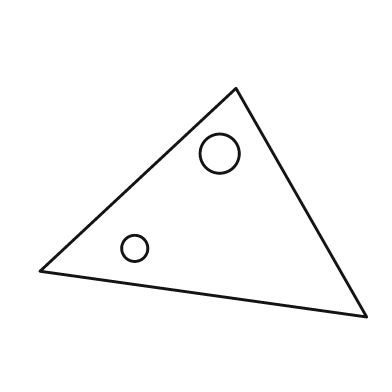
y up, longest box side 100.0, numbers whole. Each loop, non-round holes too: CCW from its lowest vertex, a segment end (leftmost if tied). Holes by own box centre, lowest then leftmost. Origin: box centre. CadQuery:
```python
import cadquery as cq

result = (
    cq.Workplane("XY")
    .moveTo(50.0, -35.0)
    .lineTo(10.0, 35.0)
    .lineTo(-50.0, -21.0)
    .close()
    .moveTo(-21.0, -14.0)
    .circle(4.0)
    .moveTo(5.0, 15.0)
    .circle(6.0)
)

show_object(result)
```